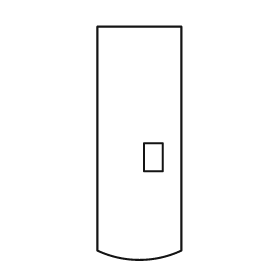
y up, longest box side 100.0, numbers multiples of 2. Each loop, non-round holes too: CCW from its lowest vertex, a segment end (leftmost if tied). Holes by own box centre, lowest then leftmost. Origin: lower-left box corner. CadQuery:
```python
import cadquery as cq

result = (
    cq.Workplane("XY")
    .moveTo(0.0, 4.0)
    .threePointArc((18.0, 0.0), (36.0, 4.0))
    .lineTo(36.0, 100.0)
    .lineTo(0.0, 100.0)
    .close()
    .moveTo(20.0, 38.0)
    .lineTo(28.0, 38.0)
    .lineTo(28.0, 50.0)
    .lineTo(20.0, 50.0)
    .close()
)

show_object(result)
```